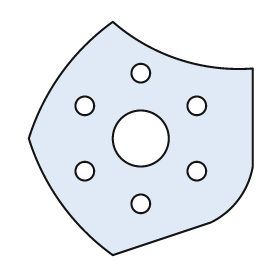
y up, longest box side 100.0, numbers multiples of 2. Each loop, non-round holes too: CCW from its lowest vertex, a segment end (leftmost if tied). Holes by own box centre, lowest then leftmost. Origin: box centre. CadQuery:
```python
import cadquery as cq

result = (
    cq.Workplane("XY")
    .moveTo(-12.0, -50.0)
    .lineTo(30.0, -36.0)
    .threePointArc((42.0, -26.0), (48.0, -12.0))
    .lineTo(48.0, 30.0)
    .threePointArc((16.0, 34.0), (-12.0, 50.0))
    .threePointArc((-34.0, 28.0), (-48.0, 0.0))
    .threePointArc((-34.0, -28.0), (-12.0, -50.0))
    .close()
    .moveTo(0.0, -28.0)
    .circle(4.0)
    .moveTo(-24.0, -14.0)
    .circle(4.0)
    .moveTo(24.0, -14.0)
    .circle(4.0)
    .moveTo(0.0, 0.0)
    .circle(12.0)
    .moveTo(-24.0, 14.0)
    .circle(4.0)
    .moveTo(24.0, 14.0)
    .circle(4.0)
    .moveTo(0.0, 28.0)
    .circle(4.0)
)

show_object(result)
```